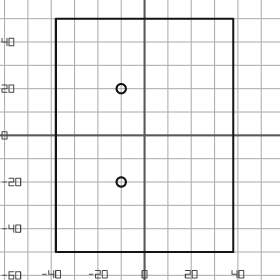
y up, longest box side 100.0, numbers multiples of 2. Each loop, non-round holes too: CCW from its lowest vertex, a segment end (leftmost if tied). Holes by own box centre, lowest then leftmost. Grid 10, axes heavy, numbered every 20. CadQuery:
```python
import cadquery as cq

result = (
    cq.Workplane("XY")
    .moveTo(-38.0, -50.0)
    .lineTo(38.0, -50.0)
    .lineTo(38.0, 50.0)
    .lineTo(-38.0, 50.0)
    .close()
    .moveTo(-10.0, -20.0)
    .circle(2.0)
    .moveTo(-10.0, 20.0)
    .circle(2.0)
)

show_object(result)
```